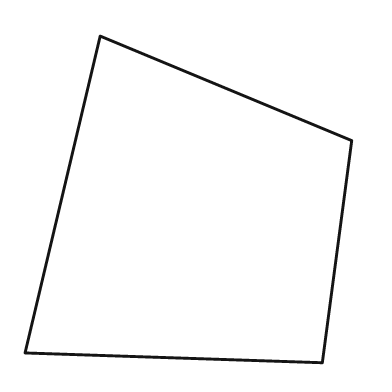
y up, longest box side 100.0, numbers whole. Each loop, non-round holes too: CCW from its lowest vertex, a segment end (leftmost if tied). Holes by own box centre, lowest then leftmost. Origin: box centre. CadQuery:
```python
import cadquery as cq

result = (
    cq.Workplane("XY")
    .moveTo(41.0, -50.0)
    .lineTo(50.0, 18.0)
    .lineTo(-27.0, 50.0)
    .lineTo(-50.0, -47.0)
    .close()
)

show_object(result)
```